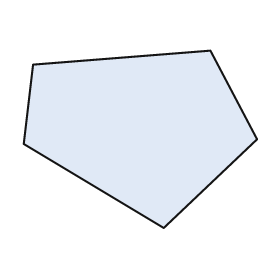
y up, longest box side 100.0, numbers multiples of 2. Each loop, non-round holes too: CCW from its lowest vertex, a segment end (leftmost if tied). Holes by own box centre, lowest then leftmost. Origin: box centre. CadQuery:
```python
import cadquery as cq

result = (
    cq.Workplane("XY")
    .moveTo(10.0, -38.0)
    .lineTo(50.0, 0.0)
    .lineTo(30.0, 38.0)
    .lineTo(-46.0, 32.0)
    .lineTo(-50.0, -2.0)
    .close()
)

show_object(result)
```